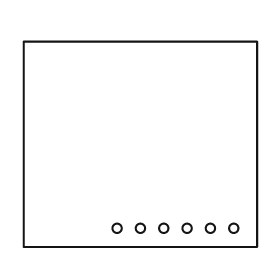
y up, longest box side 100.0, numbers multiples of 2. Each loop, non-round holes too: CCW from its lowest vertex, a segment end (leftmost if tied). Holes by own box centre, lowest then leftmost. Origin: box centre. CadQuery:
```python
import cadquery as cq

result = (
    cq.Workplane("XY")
    .moveTo(-50.0, -44.0)
    .lineTo(50.0, -44.0)
    .lineTo(50.0, 44.0)
    .lineTo(-50.0, 44.0)
    .close()
    .moveTo(-10.0, -36.0)
    .circle(2.0)
    .moveTo(0.0, -36.0)
    .circle(2.0)
    .moveTo(10.0, -36.0)
    .circle(2.0)
    .moveTo(20.0, -36.0)
    .circle(2.0)
    .moveTo(30.0, -36.0)
    .circle(2.0)
    .moveTo(40.0, -36.0)
    .circle(2.0)
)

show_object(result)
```